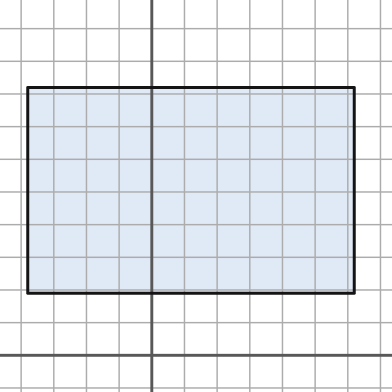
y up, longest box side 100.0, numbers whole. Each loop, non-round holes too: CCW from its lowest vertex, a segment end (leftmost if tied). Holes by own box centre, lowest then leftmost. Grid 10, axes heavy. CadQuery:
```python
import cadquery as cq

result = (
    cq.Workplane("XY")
    .moveTo(-38.0, 19.0)
    .lineTo(62.0, 19.0)
    .lineTo(62.0, 82.0)
    .lineTo(-38.0, 82.0)
    .close()
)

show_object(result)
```